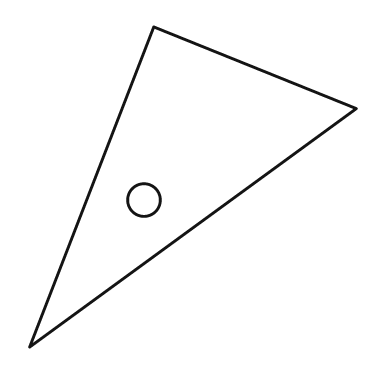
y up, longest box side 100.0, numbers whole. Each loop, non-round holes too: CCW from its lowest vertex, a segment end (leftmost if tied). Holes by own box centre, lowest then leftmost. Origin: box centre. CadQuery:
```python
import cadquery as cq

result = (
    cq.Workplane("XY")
    .moveTo(-50.0, -49.0)
    .lineTo(50.0, 24.0)
    .lineTo(-12.0, 49.0)
    .close()
    .moveTo(-15.0, -4.0)
    .circle(5.0)
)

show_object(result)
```